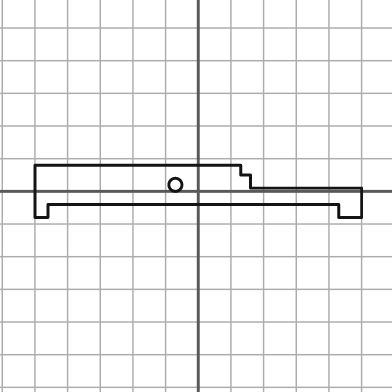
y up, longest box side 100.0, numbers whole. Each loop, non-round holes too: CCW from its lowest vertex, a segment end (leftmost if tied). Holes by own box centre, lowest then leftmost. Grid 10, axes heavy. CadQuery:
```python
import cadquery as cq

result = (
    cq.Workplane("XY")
    .moveTo(-50.0, -8.0)
    .lineTo(-46.0, -8.0)
    .lineTo(-46.0, -4.0)
    .lineTo(43.0, -4.0)
    .lineTo(43.0, -8.0)
    .lineTo(50.0, -8.0)
    .lineTo(50.0, 1.0)
    .lineTo(16.0, 1.0)
    .lineTo(16.0, 5.0)
    .lineTo(13.0, 5.0)
    .lineTo(13.0, 8.0)
    .lineTo(-50.0, 8.0)
    .close()
    .moveTo(-7.0, 2.0)
    .circle(2.0)
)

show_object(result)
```